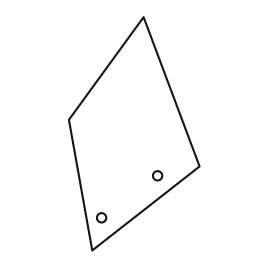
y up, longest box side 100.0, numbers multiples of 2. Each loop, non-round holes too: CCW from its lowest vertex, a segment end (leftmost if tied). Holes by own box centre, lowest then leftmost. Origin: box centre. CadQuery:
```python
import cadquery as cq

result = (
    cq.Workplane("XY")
    .moveTo(-18.0, -50.0)
    .lineTo(28.0, -14.0)
    .lineTo(4.0, 50.0)
    .lineTo(-28.0, 6.0)
    .close()
    .moveTo(-14.0, -36.0)
    .circle(2.0)
    .moveTo(10.0, -18.0)
    .circle(2.0)
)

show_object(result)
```